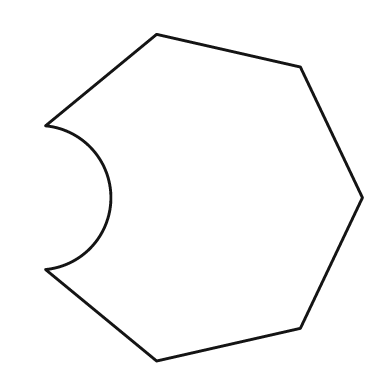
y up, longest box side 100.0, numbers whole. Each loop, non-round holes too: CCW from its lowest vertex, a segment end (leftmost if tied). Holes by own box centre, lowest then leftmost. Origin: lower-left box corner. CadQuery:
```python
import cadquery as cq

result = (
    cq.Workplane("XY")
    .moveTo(34.0, 0.0)
    .lineTo(78.0, 10.0)
    .lineTo(97.0, 50.0)
    .lineTo(78.0, 90.0)
    .lineTo(34.0, 100.0)
    .lineTo(0.0, 72.0)
    .threePointArc((20.0, 50.0), (0.0, 28.0))
    .close()
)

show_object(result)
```